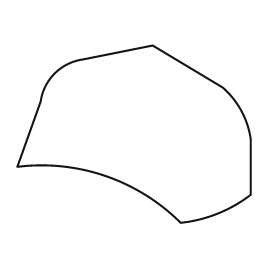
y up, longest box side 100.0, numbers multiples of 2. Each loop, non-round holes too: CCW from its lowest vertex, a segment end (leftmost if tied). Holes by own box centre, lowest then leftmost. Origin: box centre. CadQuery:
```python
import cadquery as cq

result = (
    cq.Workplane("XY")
    .moveTo(20.0, -38.0)
    .threePointArc((36.0, -34.0), (50.0, -26.0))
    .lineTo(50.0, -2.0)
    .threePointArc((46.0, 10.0), (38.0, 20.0))
    .lineTo(8.0, 38.0)
    .lineTo(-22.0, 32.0)
    .threePointArc((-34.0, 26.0), (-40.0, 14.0))
    .lineTo(-50.0, -14.0)
    .threePointArc((-12.0, -18.0), (20.0, -38.0))
    .close()
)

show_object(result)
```